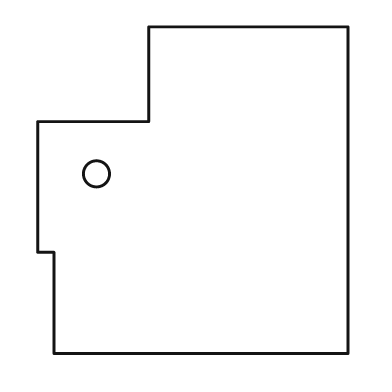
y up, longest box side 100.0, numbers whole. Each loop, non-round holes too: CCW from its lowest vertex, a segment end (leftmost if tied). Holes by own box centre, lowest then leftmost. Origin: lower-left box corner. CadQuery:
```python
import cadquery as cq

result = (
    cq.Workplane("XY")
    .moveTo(5.0, 0.0)
    .lineTo(95.0, 0.0)
    .lineTo(95.0, 100.0)
    .lineTo(34.0, 100.0)
    .lineTo(34.0, 71.0)
    .lineTo(0.0, 71.0)
    .lineTo(0.0, 31.0)
    .lineTo(5.0, 31.0)
    .close()
    .moveTo(18.0, 55.0)
    .circle(4.0)
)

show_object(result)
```